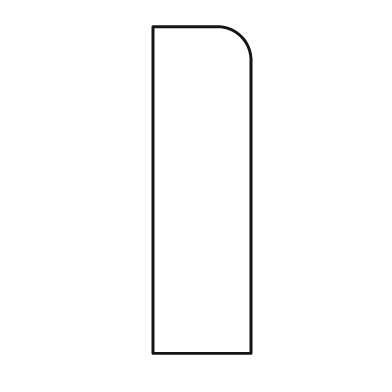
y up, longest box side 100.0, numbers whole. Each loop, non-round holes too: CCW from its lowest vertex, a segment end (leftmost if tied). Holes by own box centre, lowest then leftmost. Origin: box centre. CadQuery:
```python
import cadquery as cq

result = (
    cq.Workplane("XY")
    .moveTo(-15.0, -50.0)
    .lineTo(15.0, -50.0)
    .lineTo(15.0, 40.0)
    .threePointArc((12.0, 47.0), (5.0, 50.0))
    .lineTo(-15.0, 50.0)
    .close()
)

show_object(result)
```